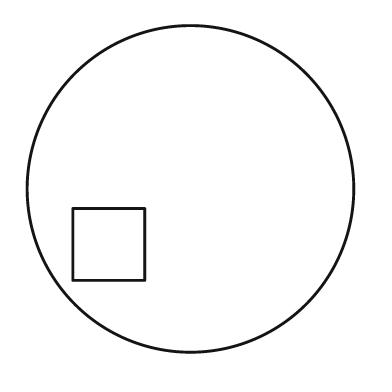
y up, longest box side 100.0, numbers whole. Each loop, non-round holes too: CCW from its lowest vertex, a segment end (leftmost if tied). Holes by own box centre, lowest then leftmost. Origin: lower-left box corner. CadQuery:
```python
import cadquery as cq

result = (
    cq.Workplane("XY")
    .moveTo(50.0, 50.0)
    .circle(50.0)
    .moveTo(14.0, 22.0)
    .lineTo(36.0, 22.0)
    .lineTo(36.0, 44.0)
    .lineTo(14.0, 44.0)
    .close()
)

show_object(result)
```